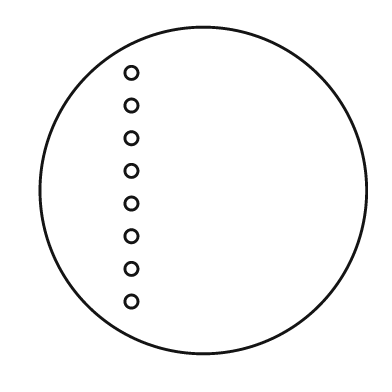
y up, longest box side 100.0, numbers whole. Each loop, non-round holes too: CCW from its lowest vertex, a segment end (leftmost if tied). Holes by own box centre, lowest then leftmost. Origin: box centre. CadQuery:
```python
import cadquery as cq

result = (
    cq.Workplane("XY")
    .moveTo(0.0, 0.0)
    .circle(50.0)
    .moveTo(-22.0, -34.0)
    .circle(2.0)
    .moveTo(-22.0, -24.0)
    .circle(2.0)
    .moveTo(-22.0, -14.0)
    .circle(2.0)
    .moveTo(-22.0, -4.0)
    .circle(2.0)
    .moveTo(-22.0, 6.0)
    .circle(2.0)
    .moveTo(-22.0, 16.0)
    .circle(2.0)
    .moveTo(-22.0, 26.0)
    .circle(2.0)
    .moveTo(-22.0, 36.0)
    .circle(2.0)
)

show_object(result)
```